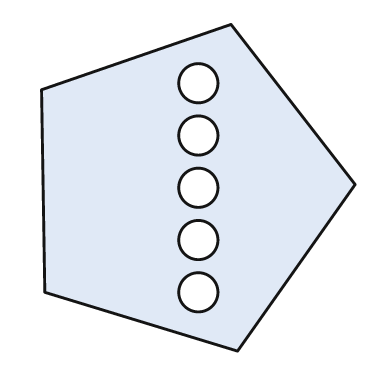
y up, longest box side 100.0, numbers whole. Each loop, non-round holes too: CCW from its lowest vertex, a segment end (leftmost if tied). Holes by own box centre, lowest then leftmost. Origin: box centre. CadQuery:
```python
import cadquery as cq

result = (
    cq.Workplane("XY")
    .moveTo(12.0, -50.0)
    .lineTo(48.0, 1.0)
    .lineTo(10.0, 50.0)
    .lineTo(-48.0, 30.0)
    .lineTo(-47.0, -32.0)
    .close()
    .moveTo(0.0, -32.0)
    .circle(6.0)
    .moveTo(0.0, -16.0)
    .circle(6.0)
    .moveTo(0.0, 0.0)
    .circle(6.0)
    .moveTo(0.0, 16.0)
    .circle(6.0)
    .moveTo(0.0, 32.0)
    .circle(6.0)
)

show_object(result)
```